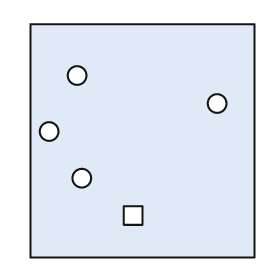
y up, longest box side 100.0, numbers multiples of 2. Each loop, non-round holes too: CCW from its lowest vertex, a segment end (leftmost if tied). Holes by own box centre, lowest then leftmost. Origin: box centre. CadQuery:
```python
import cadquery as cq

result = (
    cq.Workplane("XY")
    .moveTo(-48.0, -50.0)
    .lineTo(48.0, -50.0)
    .lineTo(48.0, 50.0)
    .lineTo(-48.0, 50.0)
    .close()
    .moveTo(-8.0, -36.0)
    .lineTo(0.0, -36.0)
    .lineTo(0.0, -28.0)
    .lineTo(-8.0, -28.0)
    .close()
    .moveTo(-26.0, -16.0)
    .circle(4.0)
    .moveTo(-40.0, 4.0)
    .circle(4.0)
    .moveTo(32.0, 16.0)
    .circle(4.0)
    .moveTo(-28.0, 28.0)
    .circle(4.0)
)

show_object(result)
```